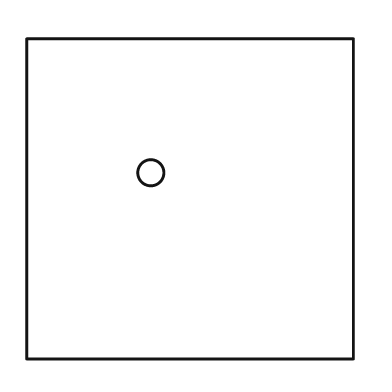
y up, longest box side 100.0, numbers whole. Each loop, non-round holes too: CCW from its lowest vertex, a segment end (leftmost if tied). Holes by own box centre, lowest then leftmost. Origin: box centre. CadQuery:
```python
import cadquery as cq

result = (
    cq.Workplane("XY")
    .moveTo(-50.0, -49.0)
    .lineTo(50.0, -49.0)
    .lineTo(50.0, 49.0)
    .lineTo(-50.0, 49.0)
    .close()
    .moveTo(-12.0, 8.0)
    .circle(4.0)
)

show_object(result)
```